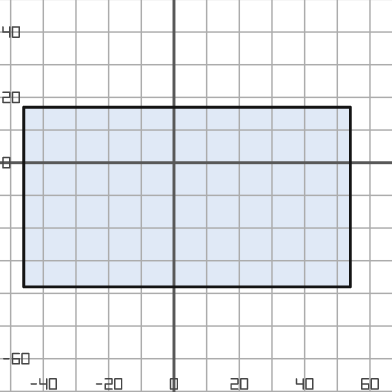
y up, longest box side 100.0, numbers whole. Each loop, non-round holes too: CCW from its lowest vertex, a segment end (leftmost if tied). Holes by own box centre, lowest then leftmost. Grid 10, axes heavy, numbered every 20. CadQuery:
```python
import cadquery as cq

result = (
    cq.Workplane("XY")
    .moveTo(-46.0, -38.0)
    .lineTo(54.0, -38.0)
    .lineTo(54.0, 17.0)
    .lineTo(-46.0, 17.0)
    .close()
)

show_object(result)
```